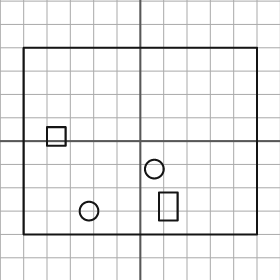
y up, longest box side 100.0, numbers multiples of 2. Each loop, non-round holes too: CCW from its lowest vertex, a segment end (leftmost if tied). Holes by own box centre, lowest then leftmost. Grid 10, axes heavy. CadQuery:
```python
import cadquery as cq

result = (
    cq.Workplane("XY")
    .moveTo(-50.0, -40.0)
    .lineTo(50.0, -40.0)
    .lineTo(50.0, 40.0)
    .lineTo(-50.0, 40.0)
    .close()
    .moveTo(-22.0, -30.0)
    .circle(4.0)
    .moveTo(8.0, -34.0)
    .lineTo(16.0, -34.0)
    .lineTo(16.0, -22.0)
    .lineTo(8.0, -22.0)
    .close()
    .moveTo(6.0, -12.0)
    .circle(4.0)
    .moveTo(-40.0, -2.0)
    .lineTo(-32.0, -2.0)
    .lineTo(-32.0, 6.0)
    .lineTo(-40.0, 6.0)
    .close()
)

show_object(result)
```